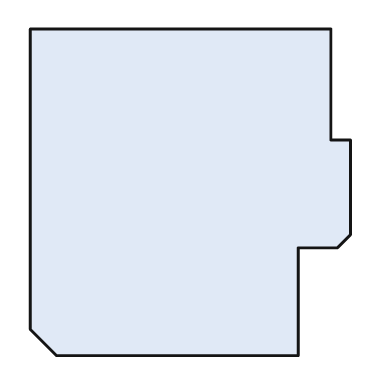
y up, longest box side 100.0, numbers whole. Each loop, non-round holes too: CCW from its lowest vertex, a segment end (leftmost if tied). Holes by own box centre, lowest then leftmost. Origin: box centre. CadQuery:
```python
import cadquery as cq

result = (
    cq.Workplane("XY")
    .moveTo(-41.0, -50.0)
    .lineTo(33.0, -50.0)
    .lineTo(33.0, -17.0)
    .lineTo(45.0, -17.0)
    .lineTo(49.0, -13.0)
    .lineTo(49.0, 16.0)
    .lineTo(43.0, 16.0)
    .lineTo(43.0, 50.0)
    .lineTo(-49.0, 50.0)
    .lineTo(-49.0, -42.0)
    .close()
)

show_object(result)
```